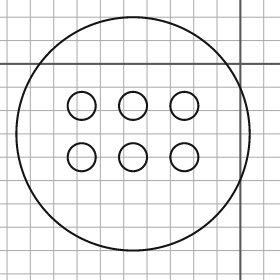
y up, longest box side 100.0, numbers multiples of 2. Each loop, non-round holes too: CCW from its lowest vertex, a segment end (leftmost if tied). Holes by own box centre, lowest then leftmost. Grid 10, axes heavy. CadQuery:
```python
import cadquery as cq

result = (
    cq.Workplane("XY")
    .moveTo(-46.0, -30.0)
    .circle(50.0)
    .moveTo(-68.0, -40.0)
    .circle(6.0)
    .moveTo(-46.0, -40.0)
    .circle(6.0)
    .moveTo(-24.0, -40.0)
    .circle(6.0)
    .moveTo(-68.0, -18.0)
    .circle(6.0)
    .moveTo(-46.0, -18.0)
    .circle(6.0)
    .moveTo(-24.0, -18.0)
    .circle(6.0)
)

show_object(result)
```